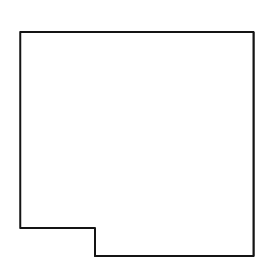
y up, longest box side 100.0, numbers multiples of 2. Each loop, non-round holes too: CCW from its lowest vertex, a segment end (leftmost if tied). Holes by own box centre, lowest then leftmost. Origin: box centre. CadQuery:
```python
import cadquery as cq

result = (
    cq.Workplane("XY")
    .moveTo(-18.0, -48.0)
    .lineTo(50.0, -48.0)
    .lineTo(50.0, 48.0)
    .lineTo(-50.0, 48.0)
    .lineTo(-50.0, -36.0)
    .lineTo(-18.0, -36.0)
    .close()
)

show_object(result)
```